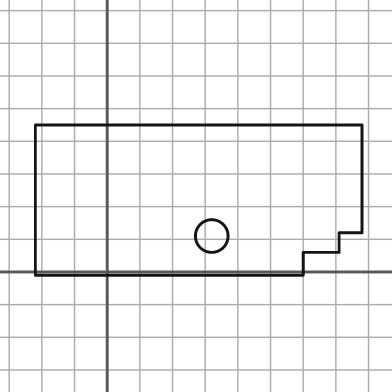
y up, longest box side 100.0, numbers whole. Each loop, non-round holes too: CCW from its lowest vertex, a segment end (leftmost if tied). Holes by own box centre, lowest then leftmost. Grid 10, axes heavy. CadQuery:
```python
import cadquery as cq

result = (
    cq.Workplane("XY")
    .moveTo(-22.0, -1.0)
    .lineTo(60.0, -1.0)
    .lineTo(60.0, 6.0)
    .lineTo(71.0, 6.0)
    .lineTo(71.0, 12.0)
    .lineTo(78.0, 12.0)
    .lineTo(78.0, 45.0)
    .lineTo(-22.0, 45.0)
    .close()
    .moveTo(32.0, 11.0)
    .circle(5.0)
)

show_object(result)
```